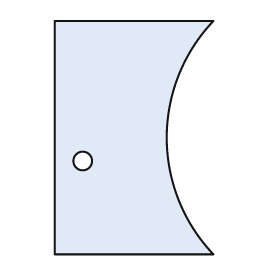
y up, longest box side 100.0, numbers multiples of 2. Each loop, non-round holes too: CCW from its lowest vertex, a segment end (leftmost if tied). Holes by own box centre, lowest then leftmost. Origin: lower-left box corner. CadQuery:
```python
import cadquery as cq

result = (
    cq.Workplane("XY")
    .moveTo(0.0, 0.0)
    .lineTo(68.0, 0.0)
    .threePointArc((48.0, 50.0), (68.0, 100.0))
    .lineTo(0.0, 100.0)
    .close()
    .moveTo(12.0, 40.0)
    .circle(4.0)
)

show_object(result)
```